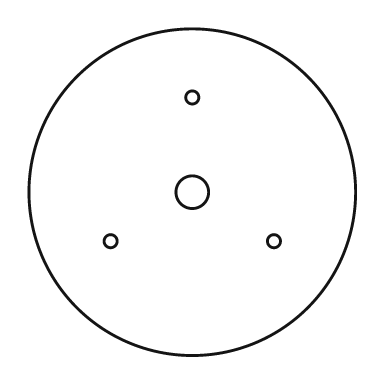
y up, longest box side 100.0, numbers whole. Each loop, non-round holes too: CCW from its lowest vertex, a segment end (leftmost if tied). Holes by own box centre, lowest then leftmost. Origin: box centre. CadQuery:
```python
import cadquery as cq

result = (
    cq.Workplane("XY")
    .moveTo(0.0, 0.0)
    .circle(50.0)
    .moveTo(-25.0, -15.0)
    .circle(2.0)
    .moveTo(25.0, -15.0)
    .circle(2.0)
    .moveTo(0.0, 0.0)
    .circle(5.0)
    .moveTo(0.0, 29.0)
    .circle(2.0)
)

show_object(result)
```